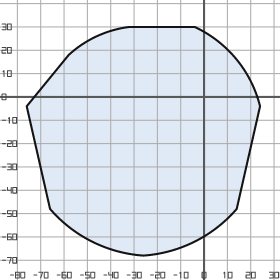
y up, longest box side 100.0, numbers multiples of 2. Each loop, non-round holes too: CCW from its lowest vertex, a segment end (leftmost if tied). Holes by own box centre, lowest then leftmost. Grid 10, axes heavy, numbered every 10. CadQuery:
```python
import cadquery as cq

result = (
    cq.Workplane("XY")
    .moveTo(-26.0, -68.0)
    .threePointArc((-4.0, -62.0), (14.0, -48.0))
    .lineTo(24.0, -4.0)
    .threePointArc((14.0, 16.0), (-4.0, 30.0))
    .lineTo(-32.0, 30.0)
    .threePointArc((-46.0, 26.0), (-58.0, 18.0))
    .lineTo(-76.0, -4.0)
    .lineTo(-66.0, -48.0)
    .threePointArc((-48.0, -62.0), (-26.0, -68.0))
    .close()
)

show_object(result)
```